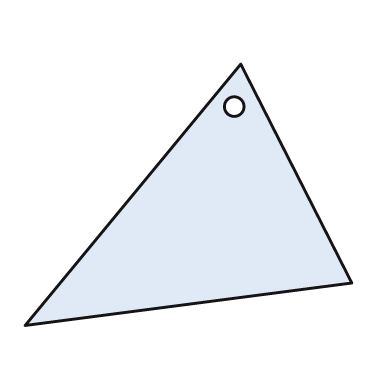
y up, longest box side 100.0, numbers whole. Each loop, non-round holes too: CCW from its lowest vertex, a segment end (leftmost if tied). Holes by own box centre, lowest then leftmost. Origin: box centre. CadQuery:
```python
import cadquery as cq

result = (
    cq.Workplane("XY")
    .moveTo(-50.0, -40.0)
    .lineTo(50.0, -27.0)
    .lineTo(16.0, 40.0)
    .close()
    .moveTo(14.0, 27.0)
    .circle(3.0)
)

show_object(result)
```